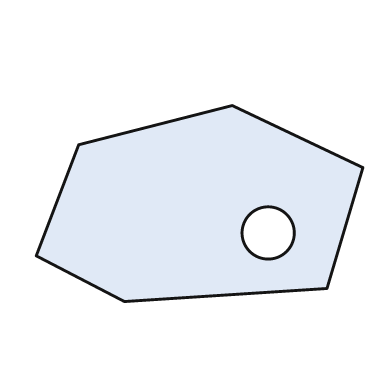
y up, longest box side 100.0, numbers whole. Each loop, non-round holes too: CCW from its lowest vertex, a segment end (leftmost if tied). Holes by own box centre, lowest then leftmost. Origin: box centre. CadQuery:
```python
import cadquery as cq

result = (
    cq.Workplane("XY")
    .moveTo(-23.0, -30.0)
    .lineTo(39.0, -26.0)
    .lineTo(50.0, 11.0)
    .lineTo(10.0, 30.0)
    .lineTo(-37.0, 18.0)
    .lineTo(-50.0, -16.0)
    .close()
    .moveTo(21.0, -9.0)
    .circle(8.0)
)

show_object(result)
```